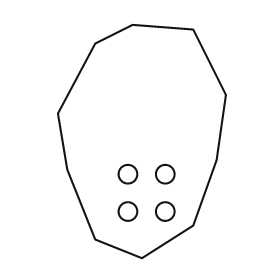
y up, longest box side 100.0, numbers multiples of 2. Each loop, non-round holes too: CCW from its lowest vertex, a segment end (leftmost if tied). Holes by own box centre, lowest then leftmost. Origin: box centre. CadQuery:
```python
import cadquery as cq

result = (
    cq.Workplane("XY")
    .moveTo(0.0, -50.0)
    .lineTo(22.0, -36.0)
    .lineTo(32.0, -8.0)
    .lineTo(36.0, 20.0)
    .lineTo(22.0, 48.0)
    .lineTo(-4.0, 50.0)
    .lineTo(-20.0, 42.0)
    .lineTo(-36.0, 12.0)
    .lineTo(-32.0, -12.0)
    .lineTo(-20.0, -42.0)
    .close()
    .moveTo(-6.0, -30.0)
    .circle(4.0)
    .moveTo(10.0, -30.0)
    .circle(4.0)
    .moveTo(-6.0, -14.0)
    .circle(4.0)
    .moveTo(10.0, -14.0)
    .circle(4.0)
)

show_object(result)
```